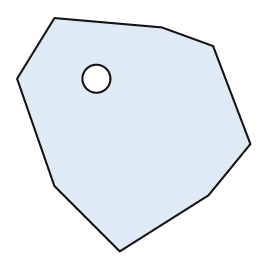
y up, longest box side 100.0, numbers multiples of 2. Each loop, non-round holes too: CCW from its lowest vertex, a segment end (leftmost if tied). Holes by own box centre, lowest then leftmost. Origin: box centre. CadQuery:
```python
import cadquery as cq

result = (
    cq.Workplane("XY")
    .moveTo(-6.0, -50.0)
    .lineTo(32.0, -26.0)
    .lineTo(50.0, -4.0)
    .lineTo(34.0, 38.0)
    .lineTo(12.0, 46.0)
    .lineTo(-34.0, 50.0)
    .lineTo(-50.0, 24.0)
    .lineTo(-34.0, -22.0)
    .close()
    .moveTo(-16.0, 24.0)
    .circle(6.0)
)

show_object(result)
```